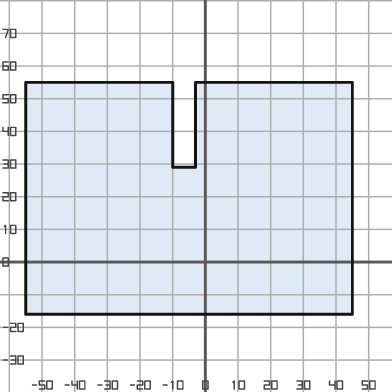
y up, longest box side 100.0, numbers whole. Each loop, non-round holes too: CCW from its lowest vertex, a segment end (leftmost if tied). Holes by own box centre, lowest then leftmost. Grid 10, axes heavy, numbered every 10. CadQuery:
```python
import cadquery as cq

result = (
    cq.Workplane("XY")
    .moveTo(-55.0, -16.0)
    .lineTo(45.0, -16.0)
    .lineTo(45.0, 55.0)
    .lineTo(-3.0, 55.0)
    .lineTo(-3.0, 29.0)
    .lineTo(-10.0, 29.0)
    .lineTo(-10.0, 55.0)
    .lineTo(-55.0, 55.0)
    .close()
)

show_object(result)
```